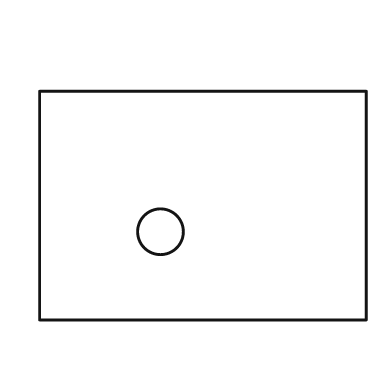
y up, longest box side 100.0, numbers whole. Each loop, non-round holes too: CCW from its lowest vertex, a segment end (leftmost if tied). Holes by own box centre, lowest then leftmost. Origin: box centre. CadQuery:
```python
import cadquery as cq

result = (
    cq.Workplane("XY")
    .moveTo(-50.0, -35.0)
    .lineTo(50.0, -35.0)
    .lineTo(50.0, 35.0)
    .lineTo(-50.0, 35.0)
    .close()
    .moveTo(-13.0, -8.0)
    .circle(7.0)
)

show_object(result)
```